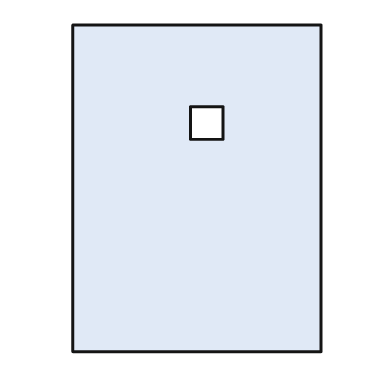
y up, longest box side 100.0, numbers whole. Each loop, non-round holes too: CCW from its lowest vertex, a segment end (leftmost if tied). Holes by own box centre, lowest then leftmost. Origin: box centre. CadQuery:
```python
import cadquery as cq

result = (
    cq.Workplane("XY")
    .moveTo(-38.0, -50.0)
    .lineTo(38.0, -50.0)
    .lineTo(38.0, 50.0)
    .lineTo(-38.0, 50.0)
    .close()
    .moveTo(-2.0, 15.0)
    .lineTo(8.0, 15.0)
    .lineTo(8.0, 25.0)
    .lineTo(-2.0, 25.0)
    .close()
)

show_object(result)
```